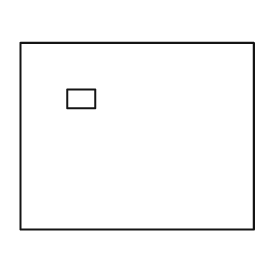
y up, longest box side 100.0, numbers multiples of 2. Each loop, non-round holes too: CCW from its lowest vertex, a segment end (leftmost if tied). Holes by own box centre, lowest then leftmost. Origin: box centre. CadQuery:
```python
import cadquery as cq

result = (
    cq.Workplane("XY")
    .moveTo(-50.0, -40.0)
    .lineTo(50.0, -40.0)
    .lineTo(50.0, 40.0)
    .lineTo(-50.0, 40.0)
    .close()
    .moveTo(-30.0, 12.0)
    .lineTo(-18.0, 12.0)
    .lineTo(-18.0, 20.0)
    .lineTo(-30.0, 20.0)
    .close()
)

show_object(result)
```